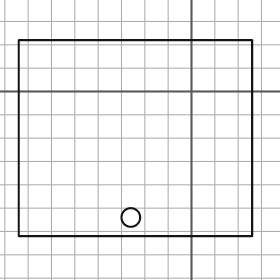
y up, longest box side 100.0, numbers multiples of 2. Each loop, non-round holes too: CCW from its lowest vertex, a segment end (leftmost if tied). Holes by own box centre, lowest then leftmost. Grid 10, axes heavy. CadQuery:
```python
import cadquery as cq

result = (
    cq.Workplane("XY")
    .moveTo(-74.0, -62.0)
    .lineTo(26.0, -62.0)
    .lineTo(26.0, 22.0)
    .lineTo(-74.0, 22.0)
    .close()
    .moveTo(-26.0, -54.0)
    .circle(4.0)
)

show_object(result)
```